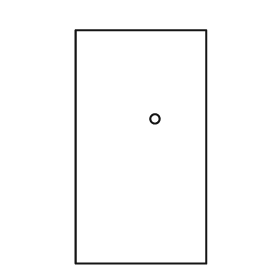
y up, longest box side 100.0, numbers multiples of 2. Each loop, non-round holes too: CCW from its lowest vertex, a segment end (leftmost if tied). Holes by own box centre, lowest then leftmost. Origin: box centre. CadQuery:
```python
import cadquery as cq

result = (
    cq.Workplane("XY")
    .moveTo(-28.0, -50.0)
    .lineTo(28.0, -50.0)
    .lineTo(28.0, 50.0)
    .lineTo(-28.0, 50.0)
    .close()
    .moveTo(6.0, 12.0)
    .circle(2.0)
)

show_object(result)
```